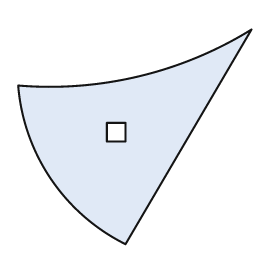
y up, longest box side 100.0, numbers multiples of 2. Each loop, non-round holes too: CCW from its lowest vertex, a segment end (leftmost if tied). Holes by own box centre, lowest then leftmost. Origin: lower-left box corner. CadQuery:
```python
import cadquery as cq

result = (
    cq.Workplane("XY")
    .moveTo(46.0, 0.0)
    .lineTo(100.0, 92.0)
    .threePointArc((52.0, 72.0), (0.0, 68.0))
    .threePointArc((14.0, 28.0), (46.0, 0.0))
    .close()
    .moveTo(38.0, 44.0)
    .lineTo(46.0, 44.0)
    .lineTo(46.0, 52.0)
    .lineTo(38.0, 52.0)
    .close()
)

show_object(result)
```